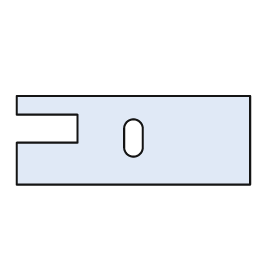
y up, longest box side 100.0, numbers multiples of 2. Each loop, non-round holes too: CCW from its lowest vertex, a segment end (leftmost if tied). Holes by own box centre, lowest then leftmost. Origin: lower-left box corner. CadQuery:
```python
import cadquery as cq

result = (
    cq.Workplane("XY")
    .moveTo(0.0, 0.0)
    .lineTo(100.0, 0.0)
    .lineTo(100.0, 38.0)
    .lineTo(0.0, 38.0)
    .lineTo(0.0, 30.0)
    .lineTo(26.0, 30.0)
    .lineTo(26.0, 18.0)
    .lineTo(0.0, 18.0)
    .close()
    .moveTo(46.0, 16.0)
    .threePointArc((50.0, 12.0), (54.0, 16.0))
    .lineTo(54.0, 24.0)
    .threePointArc((50.0, 28.0), (46.0, 24.0))
    .close()
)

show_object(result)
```